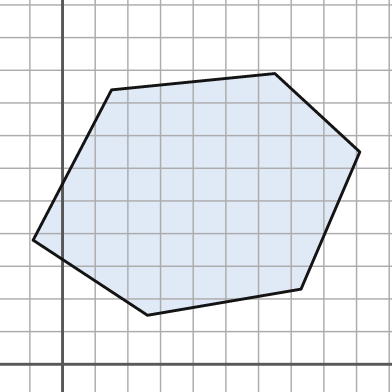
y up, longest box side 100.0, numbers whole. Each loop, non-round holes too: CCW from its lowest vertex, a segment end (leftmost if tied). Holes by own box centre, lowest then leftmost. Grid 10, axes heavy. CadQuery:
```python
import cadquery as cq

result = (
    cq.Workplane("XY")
    .moveTo(26.0, 15.0)
    .lineTo(73.0, 23.0)
    .lineTo(91.0, 65.0)
    .lineTo(65.0, 89.0)
    .lineTo(15.0, 84.0)
    .lineTo(-9.0, 38.0)
    .close()
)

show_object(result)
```